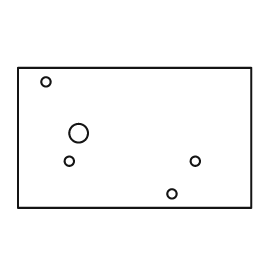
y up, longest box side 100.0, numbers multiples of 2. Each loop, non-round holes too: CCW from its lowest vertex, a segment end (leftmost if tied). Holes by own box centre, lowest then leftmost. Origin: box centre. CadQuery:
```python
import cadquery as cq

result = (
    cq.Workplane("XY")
    .moveTo(-50.0, -30.0)
    .lineTo(50.0, -30.0)
    .lineTo(50.0, 30.0)
    .lineTo(-50.0, 30.0)
    .close()
    .moveTo(16.0, -24.0)
    .circle(2.0)
    .moveTo(-28.0, -10.0)
    .circle(2.0)
    .moveTo(26.0, -10.0)
    .circle(2.0)
    .moveTo(-24.0, 2.0)
    .circle(4.0)
    .moveTo(-38.0, 24.0)
    .circle(2.0)
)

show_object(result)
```